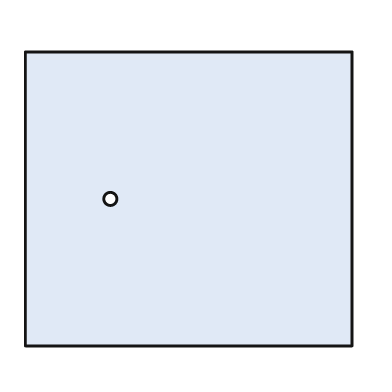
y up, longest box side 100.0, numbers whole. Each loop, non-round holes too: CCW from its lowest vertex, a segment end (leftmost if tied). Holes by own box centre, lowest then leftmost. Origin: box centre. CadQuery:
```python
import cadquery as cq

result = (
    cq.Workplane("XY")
    .moveTo(-50.0, -45.0)
    .lineTo(50.0, -45.0)
    .lineTo(50.0, 45.0)
    .lineTo(-50.0, 45.0)
    .close()
    .moveTo(-24.0, 0.0)
    .circle(2.0)
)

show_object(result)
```